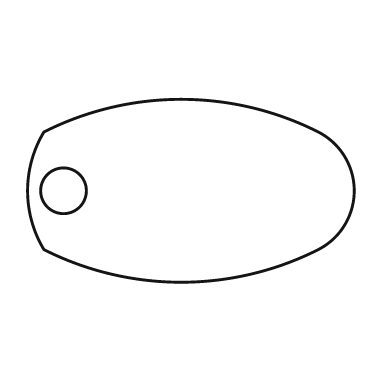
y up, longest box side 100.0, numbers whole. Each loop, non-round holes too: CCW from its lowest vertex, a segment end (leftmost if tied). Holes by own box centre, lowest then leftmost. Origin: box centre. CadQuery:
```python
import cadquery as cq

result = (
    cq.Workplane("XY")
    .moveTo(-45.0, -18.0)
    .threePointArc((-3.0, -28.0), (39.0, -18.0))
    .threePointArc((50.0, 0.0), (39.0, 18.0))
    .threePointArc((-3.0, 28.0), (-45.0, 18.0))
    .threePointArc((-50.0, 0.0), (-45.0, -18.0))
    .close()
    .moveTo(-39.0, 0.0)
    .circle(7.0)
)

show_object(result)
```